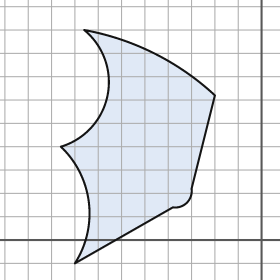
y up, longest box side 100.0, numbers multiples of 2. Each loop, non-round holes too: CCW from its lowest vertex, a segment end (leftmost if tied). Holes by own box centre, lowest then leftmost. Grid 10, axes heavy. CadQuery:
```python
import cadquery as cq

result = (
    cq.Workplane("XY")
    .moveTo(-80.0, -10.0)
    .lineTo(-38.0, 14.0)
    .threePointArc((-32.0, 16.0), (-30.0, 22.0))
    .lineTo(-20.0, 62.0)
    .threePointArc((-46.0, 80.0), (-76.0, 90.0))
    .threePointArc((-66.0, 62.0), (-86.0, 40.0))
    .threePointArc((-74.0, 16.0), (-80.0, -10.0))
    .close()
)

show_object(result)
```